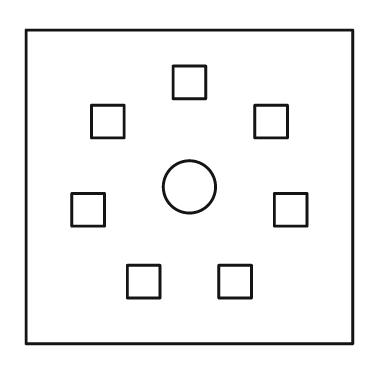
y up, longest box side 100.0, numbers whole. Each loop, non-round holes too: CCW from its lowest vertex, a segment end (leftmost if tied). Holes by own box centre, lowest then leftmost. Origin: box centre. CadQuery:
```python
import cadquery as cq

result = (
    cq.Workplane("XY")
    .moveTo(-50.0, -48.0)
    .lineTo(50.0, -48.0)
    .lineTo(50.0, 48.0)
    .lineTo(-50.0, 48.0)
    .close()
    .moveTo(-19.0, -34.0)
    .lineTo(-9.0, -34.0)
    .lineTo(-9.0, -24.0)
    .lineTo(-19.0, -24.0)
    .close()
    .moveTo(9.0, -34.0)
    .lineTo(19.0, -34.0)
    .lineTo(19.0, -24.0)
    .lineTo(9.0, -24.0)
    .close()
    .moveTo(-36.0, -12.0)
    .lineTo(-26.0, -12.0)
    .lineTo(-26.0, -2.0)
    .lineTo(-36.0, -2.0)
    .close()
    .moveTo(26.0, -12.0)
    .lineTo(36.0, -12.0)
    .lineTo(36.0, -2.0)
    .lineTo(26.0, -2.0)
    .close()
    .moveTo(0.0, 0.0)
    .circle(8.0)
    .moveTo(-30.0, 15.0)
    .lineTo(-20.0, 15.0)
    .lineTo(-20.0, 25.0)
    .lineTo(-30.0, 25.0)
    .close()
    .moveTo(20.0, 15.0)
    .lineTo(30.0, 15.0)
    .lineTo(30.0, 25.0)
    .lineTo(20.0, 25.0)
    .close()
    .moveTo(-5.0, 27.0)
    .lineTo(5.0, 27.0)
    .lineTo(5.0, 37.0)
    .lineTo(-5.0, 37.0)
    .close()
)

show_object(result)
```